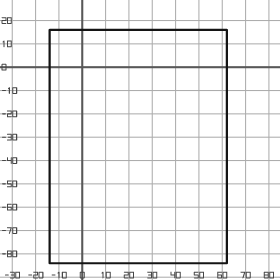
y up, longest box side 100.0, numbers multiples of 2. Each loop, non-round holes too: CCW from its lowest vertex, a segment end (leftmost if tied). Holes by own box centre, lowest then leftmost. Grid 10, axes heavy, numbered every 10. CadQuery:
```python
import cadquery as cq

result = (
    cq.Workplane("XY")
    .moveTo(-14.0, -84.0)
    .lineTo(62.0, -84.0)
    .lineTo(62.0, 16.0)
    .lineTo(-14.0, 16.0)
    .close()
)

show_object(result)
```